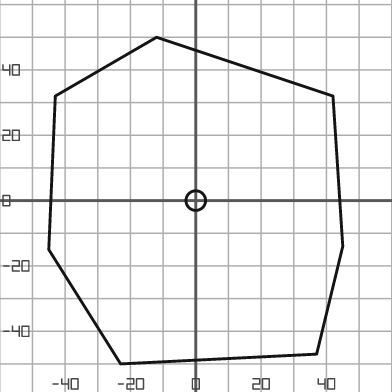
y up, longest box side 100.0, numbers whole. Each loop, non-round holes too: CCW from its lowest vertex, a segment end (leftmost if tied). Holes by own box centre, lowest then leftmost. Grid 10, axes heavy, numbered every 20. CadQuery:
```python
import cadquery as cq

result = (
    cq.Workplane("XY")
    .moveTo(-23.0, -50.0)
    .lineTo(37.0, -47.0)
    .lineTo(45.0, -14.0)
    .lineTo(42.0, 32.0)
    .lineTo(-12.0, 50.0)
    .lineTo(-43.0, 32.0)
    .lineTo(-45.0, -15.0)
    .close()
    .moveTo(0.0, 0.0)
    .circle(3.0)
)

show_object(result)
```